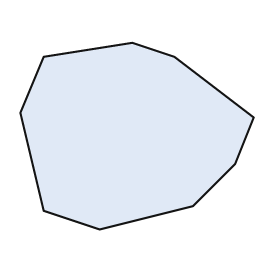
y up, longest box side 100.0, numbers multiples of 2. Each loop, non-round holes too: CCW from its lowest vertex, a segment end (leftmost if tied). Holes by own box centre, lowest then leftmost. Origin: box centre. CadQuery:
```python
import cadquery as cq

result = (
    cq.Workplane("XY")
    .moveTo(-16.0, -40.0)
    .lineTo(24.0, -30.0)
    .lineTo(42.0, -12.0)
    .lineTo(50.0, 8.0)
    .lineTo(16.0, 34.0)
    .lineTo(-2.0, 40.0)
    .lineTo(-40.0, 34.0)
    .lineTo(-50.0, 10.0)
    .lineTo(-40.0, -32.0)
    .close()
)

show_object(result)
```